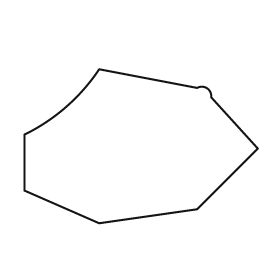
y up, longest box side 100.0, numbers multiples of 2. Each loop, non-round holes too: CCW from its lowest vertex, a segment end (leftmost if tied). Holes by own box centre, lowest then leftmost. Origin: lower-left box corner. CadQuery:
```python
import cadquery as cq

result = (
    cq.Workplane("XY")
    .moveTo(32.0, 0.0)
    .lineTo(74.0, 6.0)
    .lineTo(100.0, 32.0)
    .lineTo(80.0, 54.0)
    .threePointArc((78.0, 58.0), (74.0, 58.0))
    .lineTo(32.0, 66.0)
    .threePointArc((18.0, 50.0), (0.0, 38.0))
    .lineTo(0.0, 14.0)
    .close()
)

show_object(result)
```